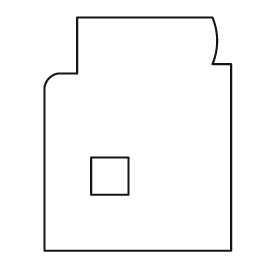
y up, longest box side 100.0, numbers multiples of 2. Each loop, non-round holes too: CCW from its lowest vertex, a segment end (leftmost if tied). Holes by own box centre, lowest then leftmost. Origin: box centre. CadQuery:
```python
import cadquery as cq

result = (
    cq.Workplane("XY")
    .moveTo(-40.0, -50.0)
    .lineTo(40.0, -50.0)
    .lineTo(40.0, 30.0)
    .lineTo(32.0, 30.0)
    .threePointArc((34.0, 40.0), (32.0, 50.0))
    .lineTo(-26.0, 50.0)
    .lineTo(-26.0, 26.0)
    .lineTo(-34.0, 26.0)
    .threePointArc((-38.0, 24.0), (-40.0, 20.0))
    .close()
    .moveTo(-20.0, -26.0)
    .lineTo(-4.0, -26.0)
    .lineTo(-4.0, -10.0)
    .lineTo(-20.0, -10.0)
    .close()
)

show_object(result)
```